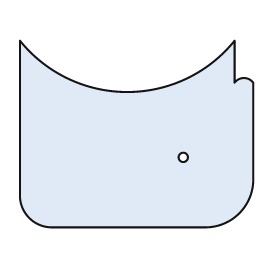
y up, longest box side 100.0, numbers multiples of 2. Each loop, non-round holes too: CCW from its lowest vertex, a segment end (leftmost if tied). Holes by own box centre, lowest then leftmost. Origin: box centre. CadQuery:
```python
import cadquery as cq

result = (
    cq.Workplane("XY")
    .moveTo(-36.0, -40.0)
    .lineTo(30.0, -40.0)
    .threePointArc((44.0, -34.0), (50.0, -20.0))
    .lineTo(50.0, 22.0)
    .threePointArc((46.0, 24.0), (42.0, 22.0))
    .lineTo(42.0, 40.0)
    .threePointArc((-4.0, 18.0), (-50.0, 40.0))
    .lineTo(-50.0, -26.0)
    .threePointArc((-46.0, -36.0), (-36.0, -40.0))
    .close()
    .moveTo(20.0, -10.0)
    .circle(2.0)
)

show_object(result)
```